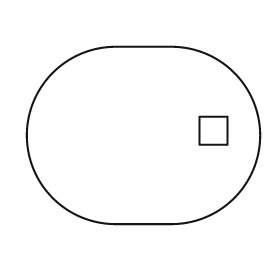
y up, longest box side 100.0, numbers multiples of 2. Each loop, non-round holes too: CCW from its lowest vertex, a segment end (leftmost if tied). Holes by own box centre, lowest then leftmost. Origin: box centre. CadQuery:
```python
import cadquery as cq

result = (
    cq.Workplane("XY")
    .moveTo(-12.0, -38.0)
    .lineTo(12.0, -38.0)
    .threePointArc((50.0, 0.0), (12.0, 38.0))
    .lineTo(-12.0, 38.0)
    .threePointArc((-50.0, 0.0), (-12.0, -38.0))
    .close()
    .moveTo(24.0, -4.0)
    .lineTo(36.0, -4.0)
    .lineTo(36.0, 8.0)
    .lineTo(24.0, 8.0)
    .close()
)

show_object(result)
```